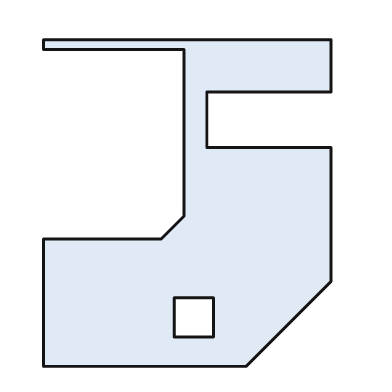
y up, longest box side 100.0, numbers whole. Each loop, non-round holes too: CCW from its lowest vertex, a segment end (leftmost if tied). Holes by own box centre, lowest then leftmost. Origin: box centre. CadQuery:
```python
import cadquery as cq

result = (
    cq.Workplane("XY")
    .moveTo(-44.0, -50.0)
    .lineTo(18.0, -50.0)
    .lineTo(44.0, -24.0)
    .lineTo(44.0, 17.0)
    .lineTo(6.0, 17.0)
    .lineTo(6.0, 34.0)
    .lineTo(44.0, 34.0)
    .lineTo(44.0, 50.0)
    .lineTo(-44.0, 50.0)
    .lineTo(-44.0, 47.0)
    .lineTo(-1.0, 47.0)
    .lineTo(-1.0, -4.0)
    .lineTo(-8.0, -11.0)
    .lineTo(-44.0, -11.0)
    .close()
    .moveTo(-4.0, -41.0)
    .lineTo(8.0, -41.0)
    .lineTo(8.0, -29.0)
    .lineTo(-4.0, -29.0)
    .close()
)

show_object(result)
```